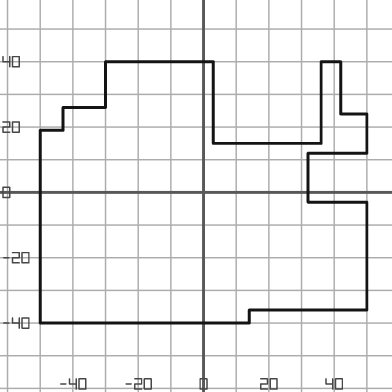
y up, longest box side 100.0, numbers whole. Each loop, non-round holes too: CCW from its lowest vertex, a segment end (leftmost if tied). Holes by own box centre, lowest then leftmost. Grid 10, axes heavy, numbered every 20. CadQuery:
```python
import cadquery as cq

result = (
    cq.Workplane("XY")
    .moveTo(-50.0, -40.0)
    .lineTo(14.0, -40.0)
    .lineTo(14.0, -36.0)
    .lineTo(50.0, -36.0)
    .lineTo(50.0, -3.0)
    .lineTo(32.0, -3.0)
    .lineTo(32.0, 12.0)
    .lineTo(50.0, 12.0)
    .lineTo(50.0, 24.0)
    .lineTo(42.0, 24.0)
    .lineTo(42.0, 40.0)
    .lineTo(36.0, 40.0)
    .lineTo(36.0, 15.0)
    .lineTo(3.0, 15.0)
    .lineTo(3.0, 40.0)
    .lineTo(-30.0, 40.0)
    .lineTo(-30.0, 26.0)
    .lineTo(-43.0, 26.0)
    .lineTo(-43.0, 19.0)
    .lineTo(-50.0, 19.0)
    .close()
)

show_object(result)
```